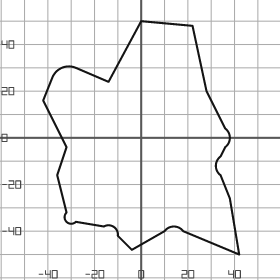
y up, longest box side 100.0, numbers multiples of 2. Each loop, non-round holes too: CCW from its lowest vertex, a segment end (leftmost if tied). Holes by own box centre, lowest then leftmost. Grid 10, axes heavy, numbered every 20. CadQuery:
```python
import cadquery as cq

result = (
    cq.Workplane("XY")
    .moveTo(42.0, -50.0)
    .lineTo(38.0, -26.0)
    .lineTo(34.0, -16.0)
    .threePointArc((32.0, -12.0), (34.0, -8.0))
    .lineTo(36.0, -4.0)
    .threePointArc((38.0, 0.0), (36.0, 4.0))
    .lineTo(28.0, 20.0)
    .lineTo(22.0, 48.0)
    .lineTo(0.0, 50.0)
    .lineTo(-14.0, 24.0)
    .lineTo(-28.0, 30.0)
    .threePointArc((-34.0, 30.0), (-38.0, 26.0))
    .lineTo(-42.0, 16.0)
    .lineTo(-32.0, -4.0)
    .lineTo(-36.0, -16.0)
    .lineTo(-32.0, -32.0)
    .threePointArc((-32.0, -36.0), (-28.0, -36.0))
    .lineTo(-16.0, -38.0)
    .threePointArc((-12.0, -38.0), (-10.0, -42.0))
    .lineTo(-4.0, -48.0)
    .lineTo(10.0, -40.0)
    .threePointArc((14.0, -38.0), (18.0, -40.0))
    .close()
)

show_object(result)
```